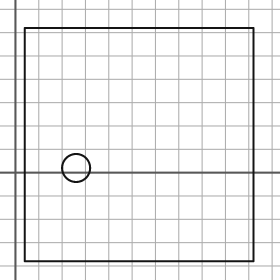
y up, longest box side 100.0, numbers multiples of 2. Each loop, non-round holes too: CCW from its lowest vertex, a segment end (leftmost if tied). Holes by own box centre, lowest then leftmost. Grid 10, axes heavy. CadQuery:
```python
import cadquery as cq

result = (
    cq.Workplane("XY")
    .moveTo(4.0, -38.0)
    .lineTo(102.0, -38.0)
    .lineTo(102.0, 62.0)
    .lineTo(4.0, 62.0)
    .close()
    .moveTo(26.0, 2.0)
    .circle(6.0)
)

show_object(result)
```